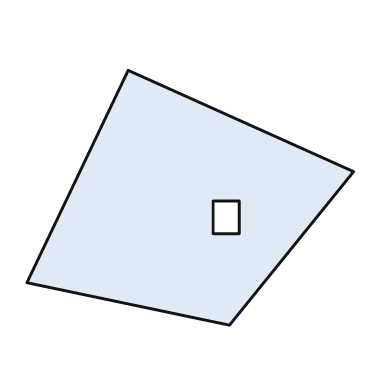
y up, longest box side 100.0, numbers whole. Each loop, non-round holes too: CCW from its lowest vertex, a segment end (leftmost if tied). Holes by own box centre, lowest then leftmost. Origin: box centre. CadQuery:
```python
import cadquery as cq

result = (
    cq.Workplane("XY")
    .moveTo(12.0, -39.0)
    .lineTo(50.0, 8.0)
    .lineTo(-19.0, 39.0)
    .lineTo(-50.0, -26.0)
    .close()
    .moveTo(7.0, -11.0)
    .lineTo(15.0, -11.0)
    .lineTo(15.0, -1.0)
    .lineTo(7.0, -1.0)
    .close()
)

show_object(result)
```